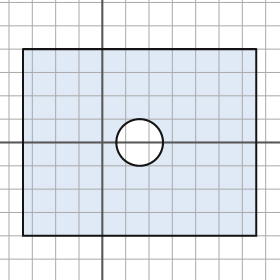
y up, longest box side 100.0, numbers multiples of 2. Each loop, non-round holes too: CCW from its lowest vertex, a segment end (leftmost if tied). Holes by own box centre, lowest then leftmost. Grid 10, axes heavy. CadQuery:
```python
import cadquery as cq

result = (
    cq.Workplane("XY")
    .moveTo(-34.0, -40.0)
    .lineTo(66.0, -40.0)
    .lineTo(66.0, 40.0)
    .lineTo(-34.0, 40.0)
    .close()
    .moveTo(16.0, 0.0)
    .circle(10.0)
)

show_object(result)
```